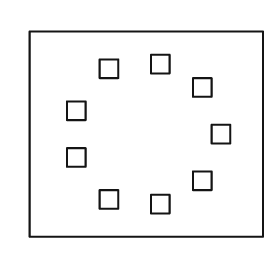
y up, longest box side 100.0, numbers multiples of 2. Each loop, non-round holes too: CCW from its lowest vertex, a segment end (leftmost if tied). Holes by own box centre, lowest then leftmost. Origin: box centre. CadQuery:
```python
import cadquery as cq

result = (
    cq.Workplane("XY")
    .moveTo(-50.0, -44.0)
    .lineTo(50.0, -44.0)
    .lineTo(50.0, 44.0)
    .lineTo(-50.0, 44.0)
    .close()
    .moveTo(2.0, -34.0)
    .lineTo(10.0, -34.0)
    .lineTo(10.0, -26.0)
    .lineTo(2.0, -26.0)
    .close()
    .moveTo(-20.0, -32.0)
    .lineTo(-12.0, -32.0)
    .lineTo(-12.0, -24.0)
    .lineTo(-20.0, -24.0)
    .close()
    .moveTo(20.0, -24.0)
    .lineTo(28.0, -24.0)
    .lineTo(28.0, -16.0)
    .lineTo(20.0, -16.0)
    .close()
    .moveTo(-34.0, -14.0)
    .lineTo(-26.0, -14.0)
    .lineTo(-26.0, -6.0)
    .lineTo(-34.0, -6.0)
    .close()
    .moveTo(28.0, -4.0)
    .lineTo(36.0, -4.0)
    .lineTo(36.0, 4.0)
    .lineTo(28.0, 4.0)
    .close()
    .moveTo(-34.0, 6.0)
    .lineTo(-26.0, 6.0)
    .lineTo(-26.0, 14.0)
    .lineTo(-34.0, 14.0)
    .close()
    .moveTo(20.0, 16.0)
    .lineTo(28.0, 16.0)
    .lineTo(28.0, 24.0)
    .lineTo(20.0, 24.0)
    .close()
    .moveTo(-20.0, 24.0)
    .lineTo(-12.0, 24.0)
    .lineTo(-12.0, 32.0)
    .lineTo(-20.0, 32.0)
    .close()
    .moveTo(2.0, 26.0)
    .lineTo(10.0, 26.0)
    .lineTo(10.0, 34.0)
    .lineTo(2.0, 34.0)
    .close()
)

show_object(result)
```